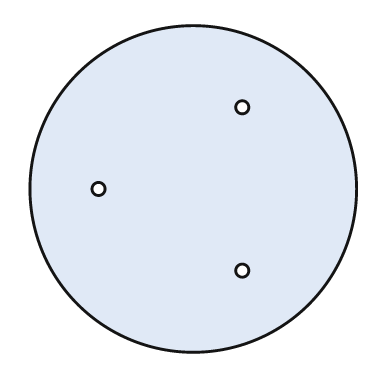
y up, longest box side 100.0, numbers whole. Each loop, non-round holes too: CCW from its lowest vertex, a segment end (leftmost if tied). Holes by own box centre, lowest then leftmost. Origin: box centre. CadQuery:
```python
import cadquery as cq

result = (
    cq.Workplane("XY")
    .moveTo(0.0, 0.0)
    .circle(50.0)
    .moveTo(15.0, -25.0)
    .circle(2.0)
    .moveTo(-29.0, 0.0)
    .circle(2.0)
    .moveTo(15.0, 25.0)
    .circle(2.0)
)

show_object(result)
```